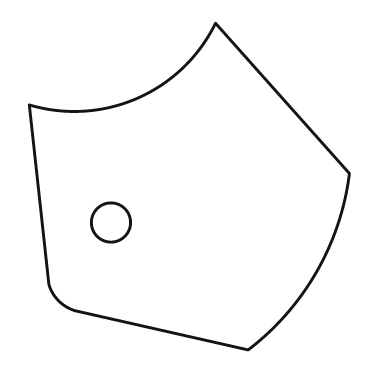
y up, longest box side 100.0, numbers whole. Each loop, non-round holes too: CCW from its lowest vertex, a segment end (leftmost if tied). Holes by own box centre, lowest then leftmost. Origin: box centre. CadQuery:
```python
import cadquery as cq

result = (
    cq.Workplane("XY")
    .moveTo(18.0, -50.0)
    .threePointArc((39.0, -26.0), (49.0, 4.0))
    .lineTo(8.0, 50.0)
    .threePointArc((-16.0, 27.0), (-49.0, 25.0))
    .lineTo(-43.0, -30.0)
    .threePointArc((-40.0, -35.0), (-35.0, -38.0))
    .close()
    .moveTo(-24.0, -11.0)
    .circle(6.0)
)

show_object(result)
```